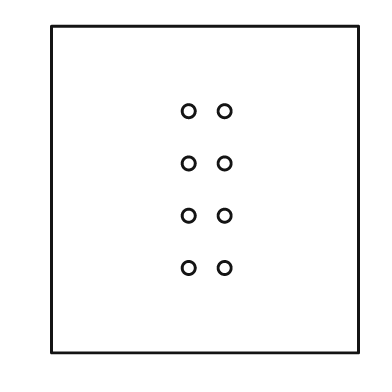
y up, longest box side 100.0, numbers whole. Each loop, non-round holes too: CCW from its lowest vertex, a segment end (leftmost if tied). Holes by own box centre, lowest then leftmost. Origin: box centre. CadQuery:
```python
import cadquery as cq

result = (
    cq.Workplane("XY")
    .moveTo(-47.0, -50.0)
    .lineTo(47.0, -50.0)
    .lineTo(47.0, 50.0)
    .lineTo(-47.0, 50.0)
    .close()
    .moveTo(-5.0, -24.0)
    .circle(2.0)
    .moveTo(6.0, -24.0)
    .circle(2.0)
    .moveTo(-5.0, -8.0)
    .circle(2.0)
    .moveTo(6.0, -8.0)
    .circle(2.0)
    .moveTo(-5.0, 8.0)
    .circle(2.0)
    .moveTo(6.0, 8.0)
    .circle(2.0)
    .moveTo(-5.0, 24.0)
    .circle(2.0)
    .moveTo(6.0, 24.0)
    .circle(2.0)
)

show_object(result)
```